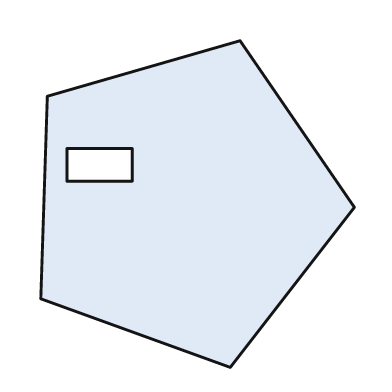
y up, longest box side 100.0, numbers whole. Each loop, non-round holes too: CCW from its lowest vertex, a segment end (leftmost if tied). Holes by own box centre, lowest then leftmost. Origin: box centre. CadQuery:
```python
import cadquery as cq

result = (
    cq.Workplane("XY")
    .moveTo(10.0, -50.0)
    .lineTo(48.0, -1.0)
    .lineTo(13.0, 50.0)
    .lineTo(-46.0, 33.0)
    .lineTo(-48.0, -29.0)
    .close()
    .moveTo(-40.0, 7.0)
    .lineTo(-20.0, 7.0)
    .lineTo(-20.0, 17.0)
    .lineTo(-40.0, 17.0)
    .close()
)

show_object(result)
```